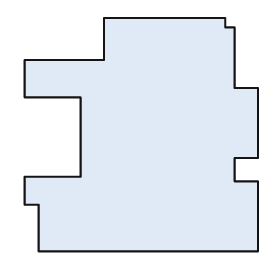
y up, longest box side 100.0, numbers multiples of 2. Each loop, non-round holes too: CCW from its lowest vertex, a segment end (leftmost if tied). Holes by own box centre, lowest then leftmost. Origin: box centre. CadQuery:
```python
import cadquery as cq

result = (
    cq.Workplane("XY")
    .moveTo(-44.0, -50.0)
    .lineTo(50.0, -50.0)
    .lineTo(50.0, -20.0)
    .lineTo(40.0, -20.0)
    .lineTo(40.0, -10.0)
    .lineTo(50.0, -10.0)
    .lineTo(50.0, 20.0)
    .lineTo(40.0, 20.0)
    .lineTo(40.0, 46.0)
    .lineTo(36.0, 46.0)
    .lineTo(36.0, 50.0)
    .lineTo(-16.0, 50.0)
    .lineTo(-16.0, 32.0)
    .lineTo(-50.0, 32.0)
    .lineTo(-50.0, 16.0)
    .lineTo(-26.0, 16.0)
    .lineTo(-26.0, -18.0)
    .lineTo(-50.0, -18.0)
    .lineTo(-50.0, -30.0)
    .lineTo(-44.0, -30.0)
    .close()
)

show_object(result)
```